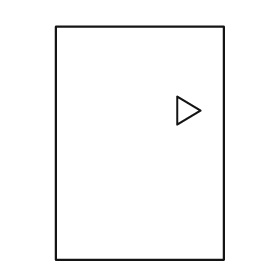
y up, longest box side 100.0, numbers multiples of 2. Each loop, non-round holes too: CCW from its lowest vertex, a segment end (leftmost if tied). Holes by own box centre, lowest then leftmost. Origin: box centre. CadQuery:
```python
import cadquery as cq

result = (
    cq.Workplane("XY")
    .moveTo(-36.0, -50.0)
    .lineTo(36.0, -50.0)
    .lineTo(36.0, 50.0)
    .lineTo(-36.0, 50.0)
    .close()
    .moveTo(16.0, 8.0)
    .lineTo(26.0, 14.0)
    .lineTo(16.0, 20.0)
    .close()
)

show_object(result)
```